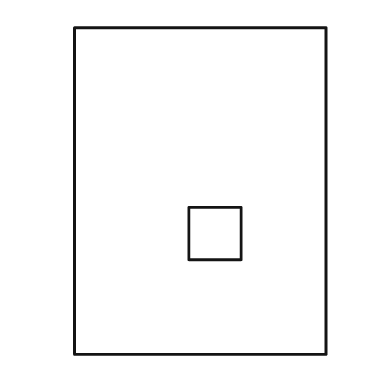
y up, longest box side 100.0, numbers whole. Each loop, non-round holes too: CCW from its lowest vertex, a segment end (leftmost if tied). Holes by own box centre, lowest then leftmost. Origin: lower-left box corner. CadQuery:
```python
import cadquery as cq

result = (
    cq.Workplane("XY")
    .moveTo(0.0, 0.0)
    .lineTo(77.0, 0.0)
    .lineTo(77.0, 100.0)
    .lineTo(0.0, 100.0)
    .close()
    .moveTo(35.0, 29.0)
    .lineTo(51.0, 29.0)
    .lineTo(51.0, 45.0)
    .lineTo(35.0, 45.0)
    .close()
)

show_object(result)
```